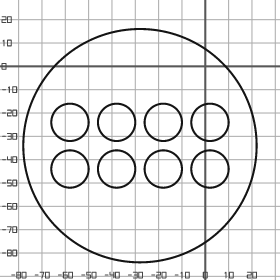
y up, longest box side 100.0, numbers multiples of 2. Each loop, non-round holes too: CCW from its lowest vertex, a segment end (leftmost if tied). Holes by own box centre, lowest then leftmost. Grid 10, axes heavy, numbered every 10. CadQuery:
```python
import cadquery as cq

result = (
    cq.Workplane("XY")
    .moveTo(-28.0, -34.0)
    .circle(50.0)
    .moveTo(-58.0, -44.0)
    .circle(8.0)
    .moveTo(-38.0, -44.0)
    .circle(8.0)
    .moveTo(-18.0, -44.0)
    .circle(8.0)
    .moveTo(2.0, -44.0)
    .circle(8.0)
    .moveTo(-58.0, -24.0)
    .circle(8.0)
    .moveTo(-38.0, -24.0)
    .circle(8.0)
    .moveTo(-18.0, -24.0)
    .circle(8.0)
    .moveTo(2.0, -24.0)
    .circle(8.0)
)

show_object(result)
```